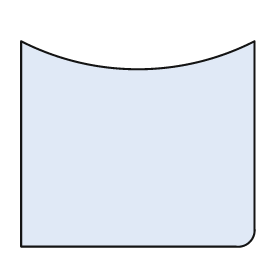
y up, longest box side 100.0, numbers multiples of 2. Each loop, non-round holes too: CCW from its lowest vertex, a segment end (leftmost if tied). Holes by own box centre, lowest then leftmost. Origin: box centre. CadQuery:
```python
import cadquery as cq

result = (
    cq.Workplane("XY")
    .moveTo(-50.0, -44.0)
    .lineTo(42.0, -44.0)
    .threePointArc((48.0, -42.0), (50.0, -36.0))
    .lineTo(50.0, 44.0)
    .threePointArc((0.0, 32.0), (-50.0, 44.0))
    .close()
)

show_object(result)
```